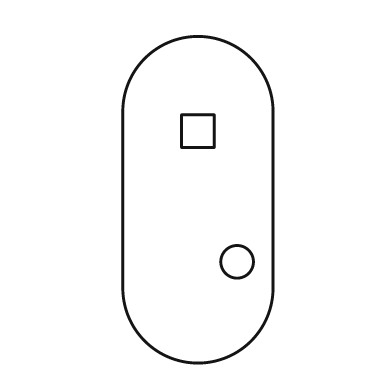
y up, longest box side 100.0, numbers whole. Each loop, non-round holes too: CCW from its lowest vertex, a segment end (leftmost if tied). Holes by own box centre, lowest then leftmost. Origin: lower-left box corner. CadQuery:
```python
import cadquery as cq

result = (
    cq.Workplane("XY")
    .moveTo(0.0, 23.0)
    .threePointArc((23.0, 0.0), (46.0, 23.0))
    .lineTo(46.0, 77.0)
    .threePointArc((23.0, 100.0), (0.0, 77.0))
    .close()
    .moveTo(35.0, 31.0)
    .circle(5.0)
    .moveTo(18.0, 66.0)
    .lineTo(28.0, 66.0)
    .lineTo(28.0, 76.0)
    .lineTo(18.0, 76.0)
    .close()
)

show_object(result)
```